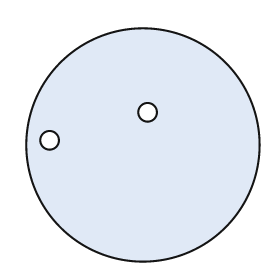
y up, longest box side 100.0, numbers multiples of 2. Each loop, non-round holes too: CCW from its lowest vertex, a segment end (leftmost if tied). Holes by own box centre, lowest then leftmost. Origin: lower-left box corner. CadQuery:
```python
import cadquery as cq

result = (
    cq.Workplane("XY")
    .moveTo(50.0, 50.0)
    .circle(50.0)
    .moveTo(10.0, 52.0)
    .circle(4.0)
    .moveTo(52.0, 64.0)
    .circle(4.0)
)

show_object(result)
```